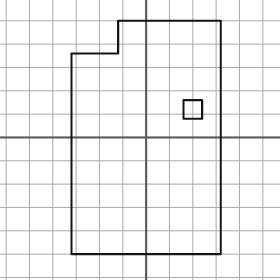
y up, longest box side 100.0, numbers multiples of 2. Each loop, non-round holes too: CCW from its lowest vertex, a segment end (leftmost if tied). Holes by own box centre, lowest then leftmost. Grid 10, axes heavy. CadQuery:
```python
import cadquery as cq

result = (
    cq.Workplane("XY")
    .moveTo(-32.0, -50.0)
    .lineTo(32.0, -50.0)
    .lineTo(32.0, 50.0)
    .lineTo(-12.0, 50.0)
    .lineTo(-12.0, 36.0)
    .lineTo(-32.0, 36.0)
    .close()
    .moveTo(16.0, 8.0)
    .lineTo(24.0, 8.0)
    .lineTo(24.0, 16.0)
    .lineTo(16.0, 16.0)
    .close()
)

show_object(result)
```